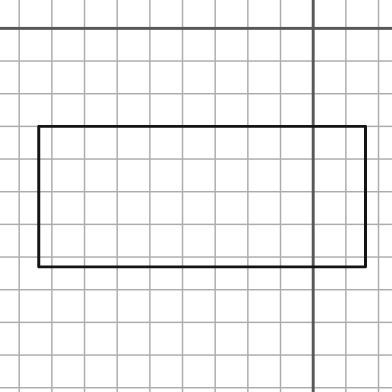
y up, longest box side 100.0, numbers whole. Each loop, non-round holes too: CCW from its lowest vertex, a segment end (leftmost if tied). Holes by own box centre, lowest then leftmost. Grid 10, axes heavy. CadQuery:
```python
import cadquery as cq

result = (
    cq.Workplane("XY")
    .moveTo(-84.0, -73.0)
    .lineTo(16.0, -73.0)
    .lineTo(16.0, -30.0)
    .lineTo(-84.0, -30.0)
    .close()
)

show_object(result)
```